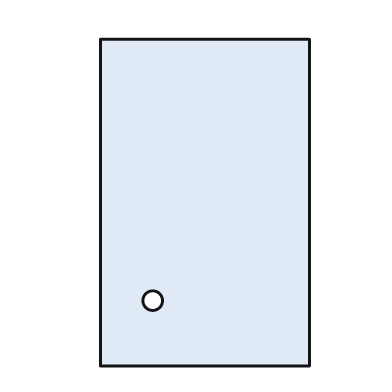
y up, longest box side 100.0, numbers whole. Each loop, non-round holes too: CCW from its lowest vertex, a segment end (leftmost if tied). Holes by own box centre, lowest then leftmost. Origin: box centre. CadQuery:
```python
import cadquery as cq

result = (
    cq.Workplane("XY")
    .moveTo(-32.0, -50.0)
    .lineTo(32.0, -50.0)
    .lineTo(32.0, 50.0)
    .lineTo(-32.0, 50.0)
    .close()
    .moveTo(-16.0, -30.0)
    .circle(3.0)
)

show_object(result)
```